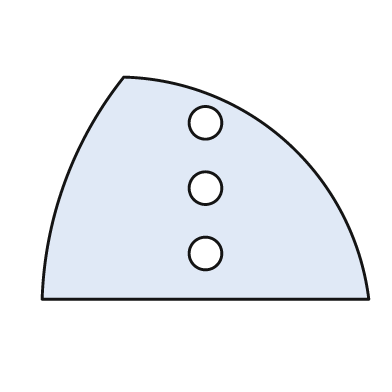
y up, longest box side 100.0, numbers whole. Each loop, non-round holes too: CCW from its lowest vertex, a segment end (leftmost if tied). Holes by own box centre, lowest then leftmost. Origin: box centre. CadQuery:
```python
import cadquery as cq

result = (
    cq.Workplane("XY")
    .moveTo(-50.0, -34.0)
    .lineTo(50.0, -34.0)
    .threePointArc((25.0, 14.0), (-25.0, 34.0))
    .threePointArc((-43.0, 2.0), (-50.0, -34.0))
    .close()
    .moveTo(0.0, -20.0)
    .circle(5.0)
    .moveTo(0.0, 0.0)
    .circle(5.0)
    .moveTo(0.0, 20.0)
    .circle(5.0)
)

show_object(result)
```